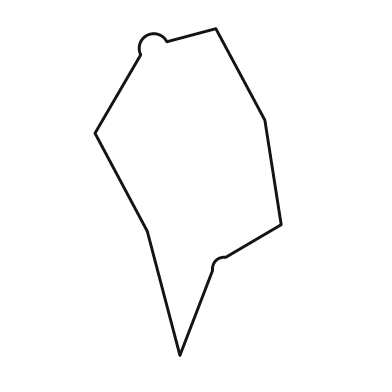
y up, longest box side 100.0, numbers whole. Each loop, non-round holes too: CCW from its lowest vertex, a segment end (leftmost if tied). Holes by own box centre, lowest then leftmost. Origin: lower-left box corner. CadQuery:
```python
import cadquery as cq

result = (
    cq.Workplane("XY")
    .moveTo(26.0, 0.0)
    .lineTo(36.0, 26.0)
    .threePointArc((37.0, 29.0), (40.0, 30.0))
    .lineTo(57.0, 40.0)
    .lineTo(52.0, 72.0)
    .lineTo(37.0, 100.0)
    .lineTo(22.0, 96.0)
    .threePointArc((16.0, 98.0), (14.0, 92.0))
    .lineTo(0.0, 68.0)
    .lineTo(16.0, 38.0)
    .close()
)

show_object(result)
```